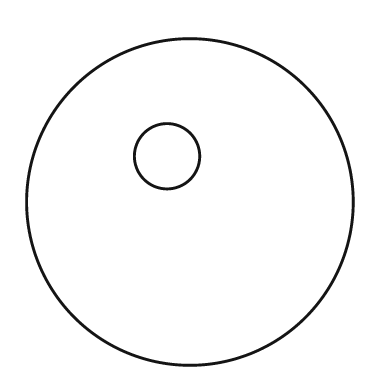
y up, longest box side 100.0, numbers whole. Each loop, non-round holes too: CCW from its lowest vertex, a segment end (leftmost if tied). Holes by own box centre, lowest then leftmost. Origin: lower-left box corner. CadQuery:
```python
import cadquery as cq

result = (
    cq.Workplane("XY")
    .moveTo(50.0, 50.0)
    .circle(50.0)
    .moveTo(43.0, 64.0)
    .circle(10.0)
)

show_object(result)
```